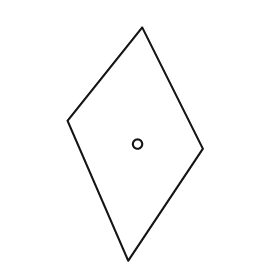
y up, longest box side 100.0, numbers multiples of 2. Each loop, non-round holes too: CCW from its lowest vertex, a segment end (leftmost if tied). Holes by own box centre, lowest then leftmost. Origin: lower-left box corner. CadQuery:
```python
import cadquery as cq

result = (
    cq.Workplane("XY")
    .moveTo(26.0, 0.0)
    .lineTo(58.0, 48.0)
    .lineTo(32.0, 100.0)
    .lineTo(0.0, 60.0)
    .close()
    .moveTo(30.0, 50.0)
    .circle(2.0)
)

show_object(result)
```